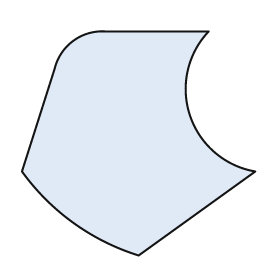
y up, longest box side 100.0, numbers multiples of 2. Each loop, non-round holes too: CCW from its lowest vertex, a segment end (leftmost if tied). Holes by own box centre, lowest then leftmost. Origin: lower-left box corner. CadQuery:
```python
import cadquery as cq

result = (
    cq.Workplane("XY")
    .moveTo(50.0, 0.0)
    .lineTo(100.0, 36.0)
    .threePointArc((72.0, 60.0), (80.0, 96.0))
    .lineTo(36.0, 96.0)
    .threePointArc((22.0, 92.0), (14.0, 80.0))
    .lineTo(0.0, 36.0)
    .threePointArc((22.0, 14.0), (50.0, 0.0))
    .close()
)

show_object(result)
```